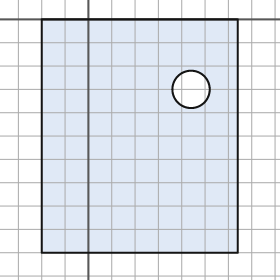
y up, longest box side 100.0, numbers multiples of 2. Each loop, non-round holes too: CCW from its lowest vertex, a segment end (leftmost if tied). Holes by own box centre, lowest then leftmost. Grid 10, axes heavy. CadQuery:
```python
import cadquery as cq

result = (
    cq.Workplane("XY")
    .moveTo(-20.0, -100.0)
    .lineTo(64.0, -100.0)
    .lineTo(64.0, 0.0)
    .lineTo(-20.0, 0.0)
    .close()
    .moveTo(44.0, -30.0)
    .circle(8.0)
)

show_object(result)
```